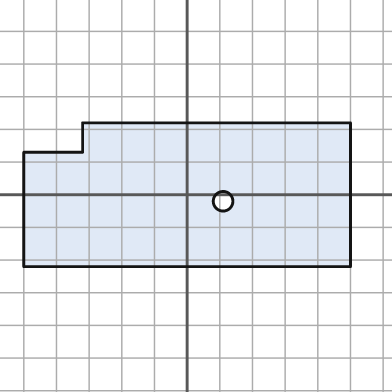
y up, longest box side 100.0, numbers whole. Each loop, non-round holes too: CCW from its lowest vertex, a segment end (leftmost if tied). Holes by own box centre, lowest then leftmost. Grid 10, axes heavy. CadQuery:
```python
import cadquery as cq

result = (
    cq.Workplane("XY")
    .moveTo(-50.0, -22.0)
    .lineTo(50.0, -22.0)
    .lineTo(50.0, 22.0)
    .lineTo(-32.0, 22.0)
    .lineTo(-32.0, 13.0)
    .lineTo(-50.0, 13.0)
    .close()
    .moveTo(11.0, -2.0)
    .circle(3.0)
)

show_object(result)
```